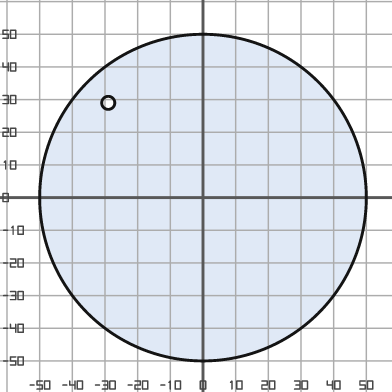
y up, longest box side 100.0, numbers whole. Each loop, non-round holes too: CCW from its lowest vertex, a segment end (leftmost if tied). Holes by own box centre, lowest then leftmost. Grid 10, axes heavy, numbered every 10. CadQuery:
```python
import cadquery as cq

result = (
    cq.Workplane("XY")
    .moveTo(0.0, 0.0)
    .circle(50.0)
    .moveTo(-29.0, 29.0)
    .circle(2.0)
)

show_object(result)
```